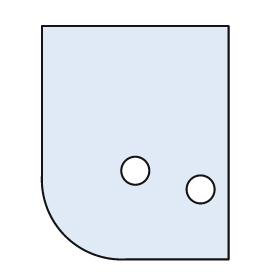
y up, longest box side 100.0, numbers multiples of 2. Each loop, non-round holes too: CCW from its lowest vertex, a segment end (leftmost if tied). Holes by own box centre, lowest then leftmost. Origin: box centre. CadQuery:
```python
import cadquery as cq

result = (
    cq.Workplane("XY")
    .moveTo(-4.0, -50.0)
    .lineTo(40.0, -50.0)
    .lineTo(40.0, 50.0)
    .lineTo(-40.0, 50.0)
    .lineTo(-40.0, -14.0)
    .threePointArc((-30.0, -40.0), (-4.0, -50.0))
    .close()
    .moveTo(28.0, -20.0)
    .circle(6.0)
    .moveTo(0.0, -12.0)
    .circle(6.0)
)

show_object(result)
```